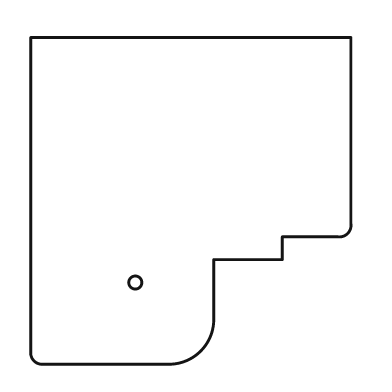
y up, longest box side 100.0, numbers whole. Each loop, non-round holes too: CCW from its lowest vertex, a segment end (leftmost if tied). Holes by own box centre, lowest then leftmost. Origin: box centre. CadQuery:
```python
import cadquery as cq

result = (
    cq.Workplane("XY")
    .moveTo(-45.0, -50.0)
    .lineTo(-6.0, -50.0)
    .threePointArc((3.0, -46.0), (7.0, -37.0))
    .lineTo(7.0, -18.0)
    .lineTo(28.0, -18.0)
    .lineTo(28.0, -11.0)
    .lineTo(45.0, -11.0)
    .threePointArc((48.0, -10.0), (49.0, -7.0))
    .lineTo(49.0, 50.0)
    .lineTo(-49.0, 50.0)
    .lineTo(-49.0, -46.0)
    .threePointArc((-48.0, -49.0), (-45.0, -50.0))
    .close()
    .moveTo(-17.0, -25.0)
    .circle(2.0)
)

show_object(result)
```